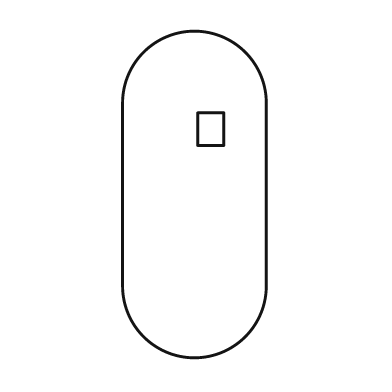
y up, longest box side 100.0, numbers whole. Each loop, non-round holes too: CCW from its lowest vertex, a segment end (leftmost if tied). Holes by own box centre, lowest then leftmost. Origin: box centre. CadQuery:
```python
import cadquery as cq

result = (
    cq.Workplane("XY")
    .moveTo(-22.0, -28.0)
    .threePointArc((0.0, -50.0), (22.0, -28.0))
    .lineTo(22.0, 28.0)
    .threePointArc((0.0, 50.0), (-22.0, 28.0))
    .close()
    .moveTo(1.0, 15.0)
    .lineTo(9.0, 15.0)
    .lineTo(9.0, 25.0)
    .lineTo(1.0, 25.0)
    .close()
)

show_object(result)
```